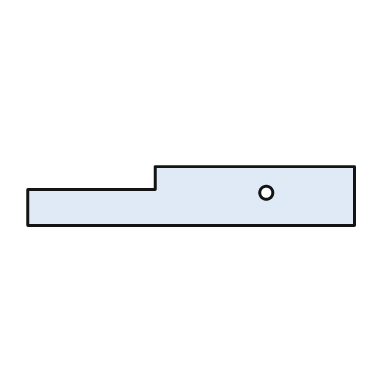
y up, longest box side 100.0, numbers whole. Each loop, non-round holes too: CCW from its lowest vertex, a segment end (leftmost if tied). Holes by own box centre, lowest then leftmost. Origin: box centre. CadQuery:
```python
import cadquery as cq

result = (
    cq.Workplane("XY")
    .moveTo(-50.0, -9.0)
    .lineTo(50.0, -9.0)
    .lineTo(50.0, 9.0)
    .lineTo(-11.0, 9.0)
    .lineTo(-11.0, 2.0)
    .lineTo(-50.0, 2.0)
    .close()
    .moveTo(23.0, 1.0)
    .circle(2.0)
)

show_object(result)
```